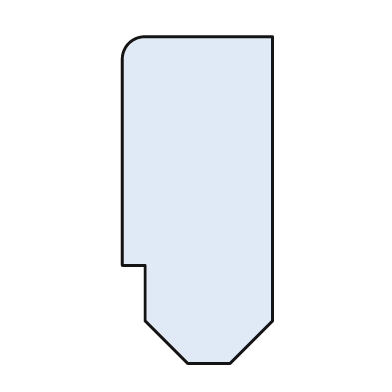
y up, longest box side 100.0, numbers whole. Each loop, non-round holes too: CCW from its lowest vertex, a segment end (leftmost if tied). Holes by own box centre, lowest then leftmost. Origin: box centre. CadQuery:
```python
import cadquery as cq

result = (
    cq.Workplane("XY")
    .moveTo(-3.0, -50.0)
    .lineTo(10.0, -50.0)
    .lineTo(23.0, -37.0)
    .lineTo(23.0, 50.0)
    .lineTo(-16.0, 50.0)
    .threePointArc((-21.0, 48.0), (-23.0, 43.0))
    .lineTo(-23.0, -20.0)
    .lineTo(-16.0, -20.0)
    .lineTo(-16.0, -37.0)
    .close()
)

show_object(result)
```